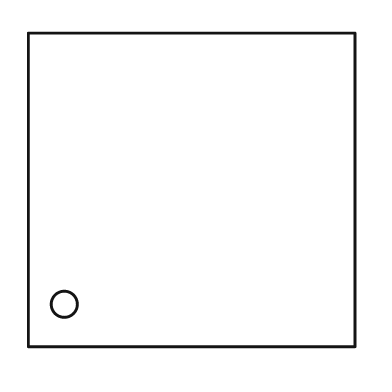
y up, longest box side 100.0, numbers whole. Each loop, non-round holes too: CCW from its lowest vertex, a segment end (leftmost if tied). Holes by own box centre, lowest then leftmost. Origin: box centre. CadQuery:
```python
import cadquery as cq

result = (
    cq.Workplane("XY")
    .moveTo(-50.0, -48.0)
    .lineTo(50.0, -48.0)
    .lineTo(50.0, 48.0)
    .lineTo(-50.0, 48.0)
    .close()
    .moveTo(-39.0, -35.0)
    .circle(4.0)
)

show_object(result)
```